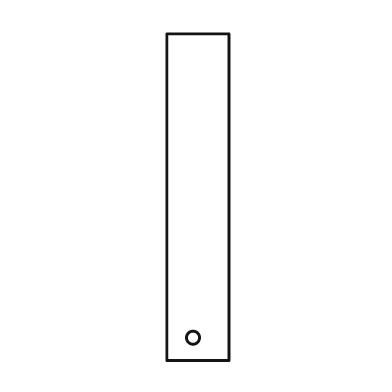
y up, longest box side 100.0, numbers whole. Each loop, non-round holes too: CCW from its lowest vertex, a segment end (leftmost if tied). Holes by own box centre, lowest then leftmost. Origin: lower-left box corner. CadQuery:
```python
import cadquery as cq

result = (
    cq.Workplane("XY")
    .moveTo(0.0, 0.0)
    .lineTo(19.0, 0.0)
    .lineTo(19.0, 100.0)
    .lineTo(0.0, 100.0)
    .close()
    .moveTo(8.0, 7.0)
    .circle(2.0)
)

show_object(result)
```